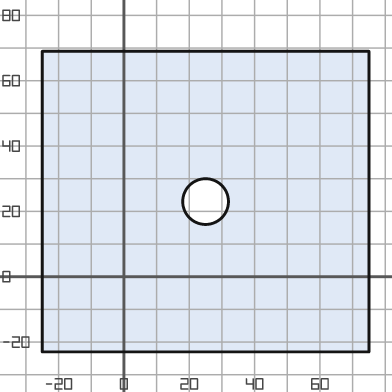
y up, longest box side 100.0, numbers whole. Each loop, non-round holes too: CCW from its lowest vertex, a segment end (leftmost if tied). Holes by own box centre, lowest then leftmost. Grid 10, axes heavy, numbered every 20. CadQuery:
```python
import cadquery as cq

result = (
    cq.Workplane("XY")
    .moveTo(-25.0, -23.0)
    .lineTo(75.0, -23.0)
    .lineTo(75.0, 69.0)
    .lineTo(-25.0, 69.0)
    .close()
    .moveTo(25.0, 23.0)
    .circle(7.0)
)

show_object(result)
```